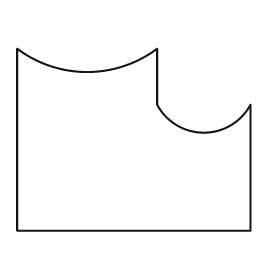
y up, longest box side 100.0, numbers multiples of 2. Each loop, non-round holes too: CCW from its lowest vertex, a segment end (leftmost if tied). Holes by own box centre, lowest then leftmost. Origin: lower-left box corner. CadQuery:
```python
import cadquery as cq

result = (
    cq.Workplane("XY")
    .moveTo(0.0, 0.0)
    .lineTo(100.0, 0.0)
    .lineTo(100.0, 54.0)
    .threePointArc((80.0, 42.0), (60.0, 54.0))
    .lineTo(60.0, 78.0)
    .threePointArc((30.0, 68.0), (0.0, 78.0))
    .close()
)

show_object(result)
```